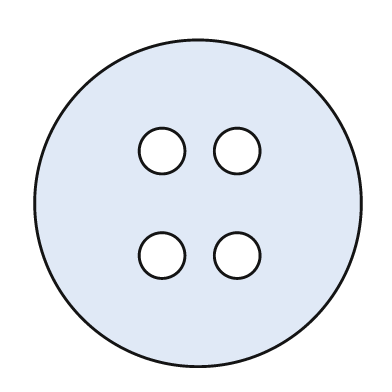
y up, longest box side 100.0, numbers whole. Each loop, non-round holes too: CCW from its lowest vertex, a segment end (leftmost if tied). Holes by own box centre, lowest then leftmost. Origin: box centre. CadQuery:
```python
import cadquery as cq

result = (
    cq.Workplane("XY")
    .moveTo(0.0, 0.0)
    .circle(50.0)
    .moveTo(-11.0, -16.0)
    .circle(7.0)
    .moveTo(12.0, -16.0)
    .circle(7.0)
    .moveTo(-11.0, 16.0)
    .circle(7.0)
    .moveTo(12.0, 16.0)
    .circle(7.0)
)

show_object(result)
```